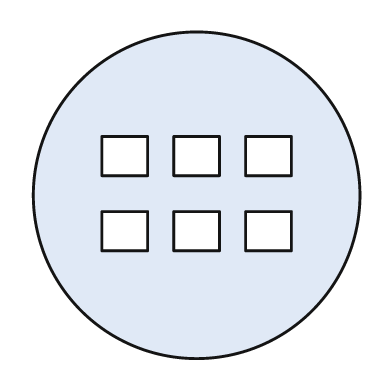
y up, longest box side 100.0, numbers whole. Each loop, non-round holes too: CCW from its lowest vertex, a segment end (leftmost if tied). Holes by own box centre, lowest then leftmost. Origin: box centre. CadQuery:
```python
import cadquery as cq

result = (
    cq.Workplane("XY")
    .moveTo(0.0, 0.0)
    .circle(50.0)
    .moveTo(-29.0, -17.0)
    .lineTo(-15.0, -17.0)
    .lineTo(-15.0, -5.0)
    .lineTo(-29.0, -5.0)
    .close()
    .moveTo(-7.0, -17.0)
    .lineTo(7.0, -17.0)
    .lineTo(7.0, -5.0)
    .lineTo(-7.0, -5.0)
    .close()
    .moveTo(15.0, -17.0)
    .lineTo(29.0, -17.0)
    .lineTo(29.0, -5.0)
    .lineTo(15.0, -5.0)
    .close()
    .moveTo(-29.0, 6.0)
    .lineTo(-15.0, 6.0)
    .lineTo(-15.0, 18.0)
    .lineTo(-29.0, 18.0)
    .close()
    .moveTo(-7.0, 6.0)
    .lineTo(7.0, 6.0)
    .lineTo(7.0, 18.0)
    .lineTo(-7.0, 18.0)
    .close()
    .moveTo(15.0, 6.0)
    .lineTo(29.0, 6.0)
    .lineTo(29.0, 18.0)
    .lineTo(15.0, 18.0)
    .close()
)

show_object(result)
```